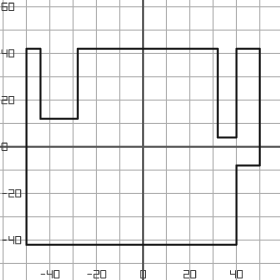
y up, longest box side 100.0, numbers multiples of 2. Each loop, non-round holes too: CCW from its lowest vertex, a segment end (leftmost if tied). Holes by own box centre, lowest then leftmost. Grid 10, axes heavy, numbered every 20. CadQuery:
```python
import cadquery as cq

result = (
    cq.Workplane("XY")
    .moveTo(-50.0, -42.0)
    .lineTo(40.0, -42.0)
    .lineTo(40.0, -8.0)
    .lineTo(50.0, -8.0)
    .lineTo(50.0, 42.0)
    .lineTo(40.0, 42.0)
    .lineTo(40.0, 4.0)
    .lineTo(32.0, 4.0)
    .lineTo(32.0, 42.0)
    .lineTo(-28.0, 42.0)
    .lineTo(-28.0, 12.0)
    .lineTo(-44.0, 12.0)
    .lineTo(-44.0, 42.0)
    .lineTo(-50.0, 42.0)
    .close()
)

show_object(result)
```